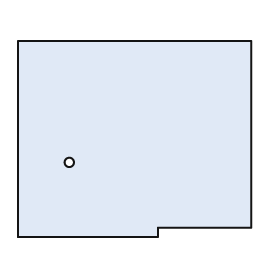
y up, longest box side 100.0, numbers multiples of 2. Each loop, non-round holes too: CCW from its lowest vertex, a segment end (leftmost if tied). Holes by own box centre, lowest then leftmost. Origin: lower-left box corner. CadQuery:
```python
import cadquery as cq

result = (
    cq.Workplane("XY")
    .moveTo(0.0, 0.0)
    .lineTo(60.0, 0.0)
    .lineTo(60.0, 4.0)
    .lineTo(100.0, 4.0)
    .lineTo(100.0, 84.0)
    .lineTo(0.0, 84.0)
    .close()
    .moveTo(22.0, 32.0)
    .circle(2.0)
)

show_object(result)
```